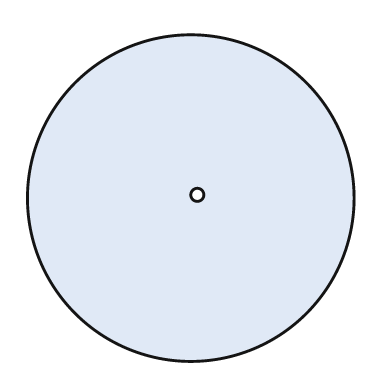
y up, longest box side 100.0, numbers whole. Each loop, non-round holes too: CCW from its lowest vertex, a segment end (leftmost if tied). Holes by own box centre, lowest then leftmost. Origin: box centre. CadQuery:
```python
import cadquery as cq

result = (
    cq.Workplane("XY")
    .moveTo(0.0, 0.0)
    .circle(50.0)
    .moveTo(2.0, 1.0)
    .circle(2.0)
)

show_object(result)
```